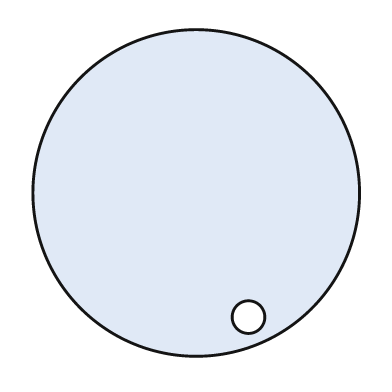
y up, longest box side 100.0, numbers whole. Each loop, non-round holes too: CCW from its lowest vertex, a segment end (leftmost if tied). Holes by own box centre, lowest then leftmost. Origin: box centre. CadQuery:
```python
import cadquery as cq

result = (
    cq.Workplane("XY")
    .moveTo(0.0, 0.0)
    .circle(50.0)
    .moveTo(16.0, -38.0)
    .circle(5.0)
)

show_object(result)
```